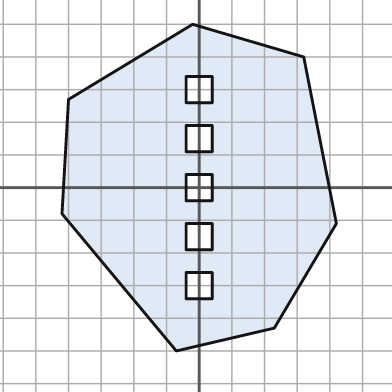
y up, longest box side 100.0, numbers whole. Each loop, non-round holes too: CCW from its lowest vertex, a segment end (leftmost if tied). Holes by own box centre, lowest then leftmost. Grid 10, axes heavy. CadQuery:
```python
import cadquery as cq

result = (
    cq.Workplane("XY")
    .moveTo(-7.0, -50.0)
    .lineTo(23.0, -43.0)
    .lineTo(42.0, -11.0)
    .lineTo(32.0, 40.0)
    .lineTo(-2.0, 50.0)
    .lineTo(-40.0, 27.0)
    .lineTo(-42.0, -8.0)
    .close()
    .moveTo(-4.0, -34.0)
    .lineTo(4.0, -34.0)
    .lineTo(4.0, -26.0)
    .lineTo(-4.0, -26.0)
    .close()
    .moveTo(-4.0, -19.0)
    .lineTo(4.0, -19.0)
    .lineTo(4.0, -11.0)
    .lineTo(-4.0, -11.0)
    .close()
    .moveTo(-4.0, -4.0)
    .lineTo(4.0, -4.0)
    .lineTo(4.0, 4.0)
    .lineTo(-4.0, 4.0)
    .close()
    .moveTo(-4.0, 11.0)
    .lineTo(4.0, 11.0)
    .lineTo(4.0, 19.0)
    .lineTo(-4.0, 19.0)
    .close()
    .moveTo(-4.0, 26.0)
    .lineTo(4.0, 26.0)
    .lineTo(4.0, 34.0)
    .lineTo(-4.0, 34.0)
    .close()
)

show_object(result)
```